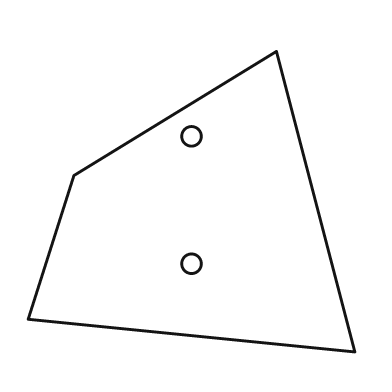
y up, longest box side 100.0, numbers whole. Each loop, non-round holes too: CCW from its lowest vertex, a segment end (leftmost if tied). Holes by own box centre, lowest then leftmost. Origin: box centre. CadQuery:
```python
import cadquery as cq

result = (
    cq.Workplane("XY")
    .moveTo(50.0, -46.0)
    .lineTo(26.0, 46.0)
    .lineTo(-36.0, 8.0)
    .lineTo(-50.0, -36.0)
    .close()
    .moveTo(0.0, -19.0)
    .circle(3.0)
    .moveTo(0.0, 20.0)
    .circle(3.0)
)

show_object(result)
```